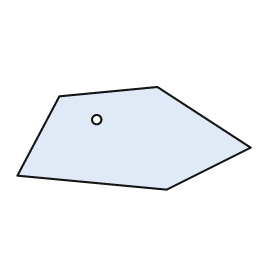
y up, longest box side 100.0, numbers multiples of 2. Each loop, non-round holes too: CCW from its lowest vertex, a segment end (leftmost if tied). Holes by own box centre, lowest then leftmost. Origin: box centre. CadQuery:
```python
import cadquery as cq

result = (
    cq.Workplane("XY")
    .moveTo(14.0, -22.0)
    .lineTo(50.0, -4.0)
    .lineTo(10.0, 22.0)
    .lineTo(-32.0, 18.0)
    .lineTo(-50.0, -16.0)
    .close()
    .moveTo(-16.0, 8.0)
    .circle(2.0)
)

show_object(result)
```